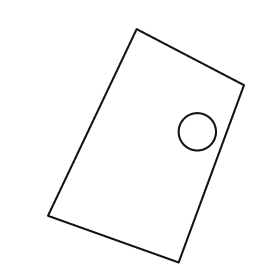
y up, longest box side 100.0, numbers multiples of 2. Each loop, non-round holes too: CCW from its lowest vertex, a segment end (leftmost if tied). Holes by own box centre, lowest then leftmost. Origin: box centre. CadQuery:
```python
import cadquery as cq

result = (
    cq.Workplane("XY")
    .moveTo(14.0, -50.0)
    .lineTo(42.0, 26.0)
    .lineTo(-4.0, 50.0)
    .lineTo(-42.0, -30.0)
    .close()
    .moveTo(22.0, 6.0)
    .circle(8.0)
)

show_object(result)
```